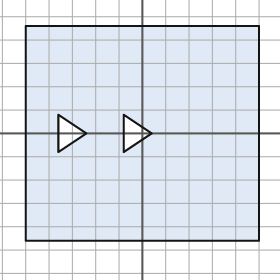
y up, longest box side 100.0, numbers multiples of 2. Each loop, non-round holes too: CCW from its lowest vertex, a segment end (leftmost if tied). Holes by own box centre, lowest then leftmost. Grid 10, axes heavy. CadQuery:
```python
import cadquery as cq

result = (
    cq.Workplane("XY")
    .moveTo(-50.0, -46.0)
    .lineTo(50.0, -46.0)
    .lineTo(50.0, 46.0)
    .lineTo(-50.0, 46.0)
    .close()
    .moveTo(-36.0, -8.0)
    .lineTo(-24.0, 0.0)
    .lineTo(-36.0, 8.0)
    .close()
    .moveTo(-8.0, -8.0)
    .lineTo(4.0, 0.0)
    .lineTo(-8.0, 8.0)
    .close()
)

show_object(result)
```